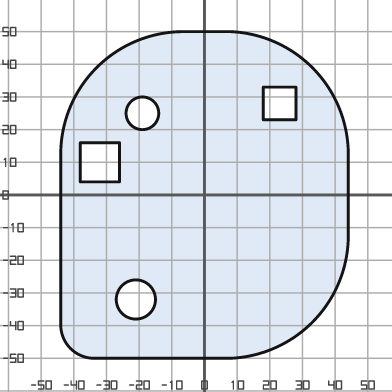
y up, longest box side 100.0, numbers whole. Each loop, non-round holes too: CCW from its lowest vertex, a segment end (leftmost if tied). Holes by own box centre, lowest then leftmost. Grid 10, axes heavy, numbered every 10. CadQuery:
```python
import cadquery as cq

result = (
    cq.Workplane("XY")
    .moveTo(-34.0, -50.0)
    .lineTo(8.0, -50.0)
    .threePointArc((33.0, -39.0), (44.0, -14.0))
    .lineTo(44.0, 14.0)
    .threePointArc((33.0, 39.0), (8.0, 50.0))
    .lineTo(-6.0, 50.0)
    .threePointArc((-33.0, 39.0), (-44.0, 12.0))
    .lineTo(-44.0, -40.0)
    .threePointArc((-41.0, -47.0), (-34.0, -50.0))
    .close()
    .moveTo(-21.0, -32.0)
    .circle(6.0)
    .moveTo(-38.0, 4.0)
    .lineTo(-26.0, 4.0)
    .lineTo(-26.0, 16.0)
    .lineTo(-38.0, 16.0)
    .close()
    .moveTo(-19.0, 25.0)
    .circle(5.0)
    .moveTo(18.0, 23.0)
    .lineTo(28.0, 23.0)
    .lineTo(28.0, 33.0)
    .lineTo(18.0, 33.0)
    .close()
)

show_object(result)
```